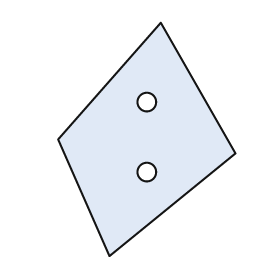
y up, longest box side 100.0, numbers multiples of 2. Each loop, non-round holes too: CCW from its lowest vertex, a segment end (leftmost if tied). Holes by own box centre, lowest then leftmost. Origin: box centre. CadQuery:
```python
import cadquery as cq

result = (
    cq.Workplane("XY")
    .moveTo(-16.0, -50.0)
    .lineTo(38.0, -6.0)
    .lineTo(6.0, 50.0)
    .lineTo(-38.0, 0.0)
    .close()
    .moveTo(0.0, -14.0)
    .circle(4.0)
    .moveTo(0.0, 16.0)
    .circle(4.0)
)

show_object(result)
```